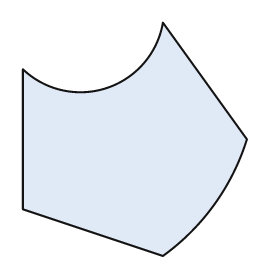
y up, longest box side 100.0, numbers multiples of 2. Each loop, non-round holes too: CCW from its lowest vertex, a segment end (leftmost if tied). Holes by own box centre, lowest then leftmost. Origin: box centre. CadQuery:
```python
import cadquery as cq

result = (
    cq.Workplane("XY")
    .moveTo(12.0, -50.0)
    .threePointArc((34.0, -28.0), (48.0, 0.0))
    .lineTo(12.0, 50.0)
    .threePointArc((-12.0, 22.0), (-48.0, 30.0))
    .lineTo(-48.0, -30.0)
    .close()
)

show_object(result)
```